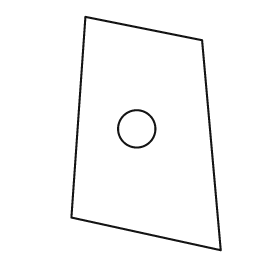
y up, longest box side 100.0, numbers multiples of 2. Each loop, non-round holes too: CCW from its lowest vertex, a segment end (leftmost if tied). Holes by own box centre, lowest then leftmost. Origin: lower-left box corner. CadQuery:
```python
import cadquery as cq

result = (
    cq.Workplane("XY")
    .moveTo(64.0, 0.0)
    .lineTo(56.0, 90.0)
    .lineTo(6.0, 100.0)
    .lineTo(0.0, 14.0)
    .close()
    .moveTo(28.0, 52.0)
    .circle(8.0)
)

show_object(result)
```